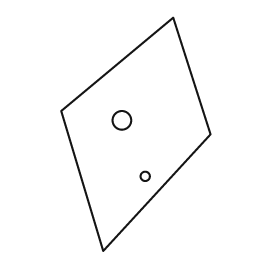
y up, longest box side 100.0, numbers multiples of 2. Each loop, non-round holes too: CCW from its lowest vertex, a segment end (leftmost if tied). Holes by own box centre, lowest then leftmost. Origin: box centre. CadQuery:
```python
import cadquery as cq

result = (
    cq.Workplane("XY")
    .moveTo(-14.0, -50.0)
    .lineTo(32.0, 0.0)
    .lineTo(16.0, 50.0)
    .lineTo(-32.0, 10.0)
    .close()
    .moveTo(4.0, -18.0)
    .circle(2.0)
    .moveTo(-6.0, 6.0)
    .circle(4.0)
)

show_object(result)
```